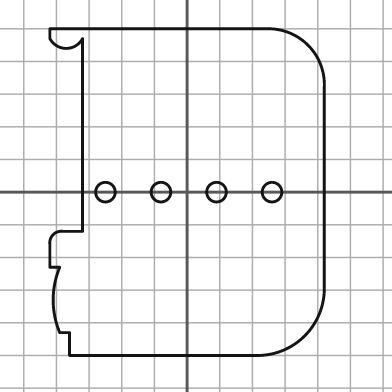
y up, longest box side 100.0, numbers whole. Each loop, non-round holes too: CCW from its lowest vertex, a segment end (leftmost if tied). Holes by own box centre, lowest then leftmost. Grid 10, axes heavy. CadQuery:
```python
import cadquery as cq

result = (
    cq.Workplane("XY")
    .moveTo(-36.0, -50.0)
    .lineTo(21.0, -50.0)
    .threePointArc((36.0, -44.0), (42.0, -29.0))
    .lineTo(42.0, 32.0)
    .threePointArc((37.0, 45.0), (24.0, 50.0))
    .lineTo(-42.0, 50.0)
    .lineTo(-42.0, 47.0)
    .threePointArc((-37.0, 44.0), (-32.0, 47.0))
    .lineTo(-32.0, -12.0)
    .lineTo(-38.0, -12.0)
    .threePointArc((-41.0, -13.0), (-42.0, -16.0))
    .lineTo(-42.0, -23.0)
    .lineTo(-39.0, -23.0)
    .threePointArc((-41.0, -33.0), (-39.0, -43.0))
    .lineTo(-36.0, -43.0)
    .close()
    .moveTo(-25.0, 0.0)
    .circle(3.0)
    .moveTo(-8.0, 0.0)
    .circle(3.0)
    .moveTo(9.0, 0.0)
    .circle(3.0)
    .moveTo(26.0, 0.0)
    .circle(3.0)
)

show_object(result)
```